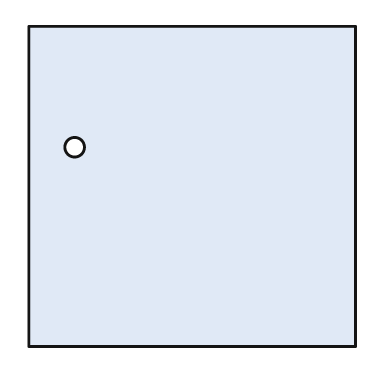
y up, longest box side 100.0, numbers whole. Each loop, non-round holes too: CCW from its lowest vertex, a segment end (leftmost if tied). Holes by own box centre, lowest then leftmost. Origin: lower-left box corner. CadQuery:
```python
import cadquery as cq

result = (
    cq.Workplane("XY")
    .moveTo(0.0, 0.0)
    .lineTo(100.0, 0.0)
    .lineTo(100.0, 98.0)
    .lineTo(0.0, 98.0)
    .close()
    .moveTo(14.0, 61.0)
    .circle(3.0)
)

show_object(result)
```